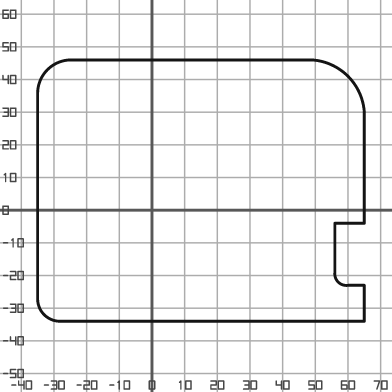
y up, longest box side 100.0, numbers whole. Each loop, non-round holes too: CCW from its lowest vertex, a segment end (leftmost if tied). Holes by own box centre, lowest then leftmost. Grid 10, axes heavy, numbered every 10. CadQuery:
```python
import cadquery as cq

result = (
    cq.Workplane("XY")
    .moveTo(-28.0, -34.0)
    .lineTo(65.0, -34.0)
    .lineTo(65.0, -23.0)
    .lineTo(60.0, -23.0)
    .threePointArc((57.0, -22.0), (56.0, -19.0))
    .lineTo(56.0, -4.0)
    .lineTo(65.0, -4.0)
    .lineTo(65.0, 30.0)
    .threePointArc((60.0, 41.0), (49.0, 46.0))
    .lineTo(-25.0, 46.0)
    .threePointArc((-32.0, 43.0), (-35.0, 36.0))
    .lineTo(-35.0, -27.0)
    .threePointArc((-33.0, -32.0), (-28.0, -34.0))
    .close()
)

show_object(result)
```